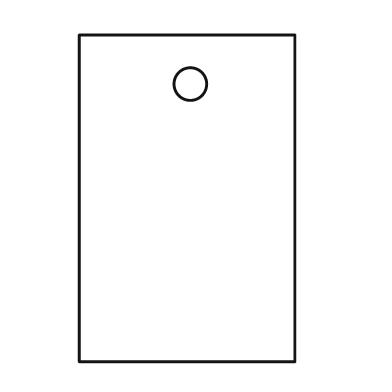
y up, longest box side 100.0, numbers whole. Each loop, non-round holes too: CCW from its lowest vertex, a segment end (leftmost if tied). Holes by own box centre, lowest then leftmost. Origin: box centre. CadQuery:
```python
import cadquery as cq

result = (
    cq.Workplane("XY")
    .moveTo(-33.0, -50.0)
    .lineTo(33.0, -50.0)
    .lineTo(33.0, 50.0)
    .lineTo(-33.0, 50.0)
    .close()
    .moveTo(1.0, 35.0)
    .circle(5.0)
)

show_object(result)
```